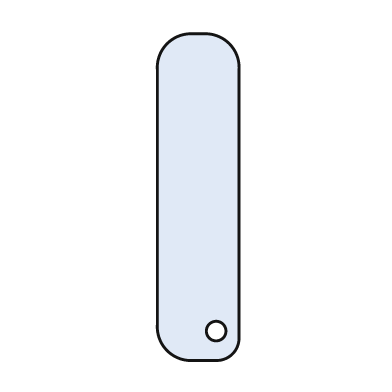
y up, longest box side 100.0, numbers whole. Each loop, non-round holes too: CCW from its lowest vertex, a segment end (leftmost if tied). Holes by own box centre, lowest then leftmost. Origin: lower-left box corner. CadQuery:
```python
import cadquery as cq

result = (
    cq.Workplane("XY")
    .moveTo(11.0, 0.0)
    .lineTo(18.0, 0.0)
    .threePointArc((23.0, 2.0), (25.0, 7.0))
    .lineTo(25.0, 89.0)
    .threePointArc((22.0, 97.0), (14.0, 100.0))
    .lineTo(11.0, 100.0)
    .threePointArc((3.0, 97.0), (0.0, 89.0))
    .lineTo(0.0, 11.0)
    .threePointArc((3.0, 3.0), (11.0, 0.0))
    .close()
    .moveTo(18.0, 9.0)
    .circle(3.0)
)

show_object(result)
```